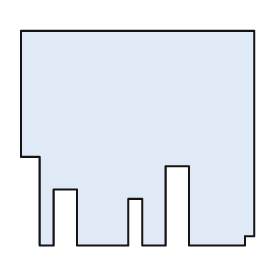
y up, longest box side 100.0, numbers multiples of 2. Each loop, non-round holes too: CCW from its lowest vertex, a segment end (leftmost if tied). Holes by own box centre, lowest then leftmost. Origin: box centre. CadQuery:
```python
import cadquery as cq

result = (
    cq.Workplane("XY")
    .moveTo(-42.0, -46.0)
    .lineTo(-36.0, -46.0)
    .lineTo(-36.0, -22.0)
    .lineTo(-26.0, -22.0)
    .lineTo(-26.0, -46.0)
    .lineTo(-4.0, -46.0)
    .lineTo(-4.0, -26.0)
    .lineTo(2.0, -26.0)
    .lineTo(2.0, -46.0)
    .lineTo(12.0, -46.0)
    .lineTo(12.0, -12.0)
    .lineTo(22.0, -12.0)
    .lineTo(22.0, -46.0)
    .lineTo(46.0, -46.0)
    .lineTo(46.0, -42.0)
    .lineTo(50.0, -42.0)
    .lineTo(50.0, 46.0)
    .lineTo(-50.0, 46.0)
    .lineTo(-50.0, -8.0)
    .lineTo(-42.0, -8.0)
    .close()
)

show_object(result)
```